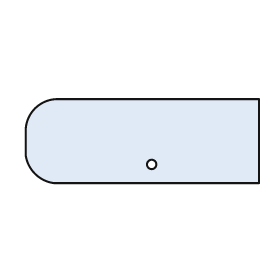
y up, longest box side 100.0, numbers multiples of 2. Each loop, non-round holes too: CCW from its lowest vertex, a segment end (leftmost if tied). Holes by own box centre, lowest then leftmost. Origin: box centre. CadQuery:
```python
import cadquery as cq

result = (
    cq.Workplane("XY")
    .moveTo(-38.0, -18.0)
    .lineTo(50.0, -18.0)
    .lineTo(50.0, 18.0)
    .lineTo(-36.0, 18.0)
    .threePointArc((-46.0, 14.0), (-50.0, 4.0))
    .lineTo(-50.0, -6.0)
    .threePointArc((-46.0, -14.0), (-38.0, -18.0))
    .close()
    .moveTo(4.0, -10.0)
    .circle(2.0)
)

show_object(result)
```